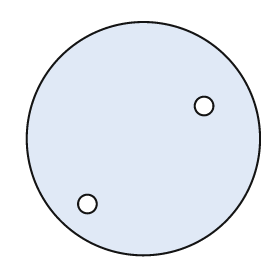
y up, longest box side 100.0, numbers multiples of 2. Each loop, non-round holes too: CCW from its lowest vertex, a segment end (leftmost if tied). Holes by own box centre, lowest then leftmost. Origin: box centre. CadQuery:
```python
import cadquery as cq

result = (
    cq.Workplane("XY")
    .moveTo(0.0, 0.0)
    .circle(50.0)
    .moveTo(-24.0, -28.0)
    .circle(4.0)
    .moveTo(26.0, 14.0)
    .circle(4.0)
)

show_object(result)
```